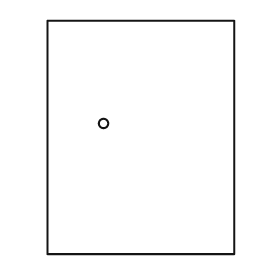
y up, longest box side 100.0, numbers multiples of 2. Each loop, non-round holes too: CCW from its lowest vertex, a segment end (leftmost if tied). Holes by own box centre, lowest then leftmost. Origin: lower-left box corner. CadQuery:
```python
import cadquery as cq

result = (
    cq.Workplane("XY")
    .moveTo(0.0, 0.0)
    .lineTo(80.0, 0.0)
    .lineTo(80.0, 100.0)
    .lineTo(0.0, 100.0)
    .close()
    .moveTo(24.0, 56.0)
    .circle(2.0)
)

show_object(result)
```